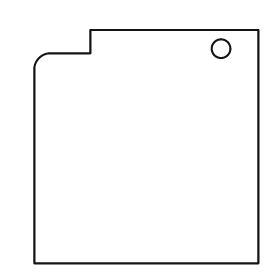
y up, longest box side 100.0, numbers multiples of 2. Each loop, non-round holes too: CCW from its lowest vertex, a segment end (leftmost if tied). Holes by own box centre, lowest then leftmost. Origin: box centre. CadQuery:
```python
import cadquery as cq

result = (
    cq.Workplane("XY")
    .moveTo(-48.0, -50.0)
    .lineTo(48.0, -50.0)
    .lineTo(48.0, 50.0)
    .lineTo(-24.0, 50.0)
    .lineTo(-24.0, 40.0)
    .lineTo(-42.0, 40.0)
    .threePointArc((-46.0, 38.0), (-48.0, 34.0))
    .close()
    .moveTo(32.0, 42.0)
    .circle(4.0)
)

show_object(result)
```